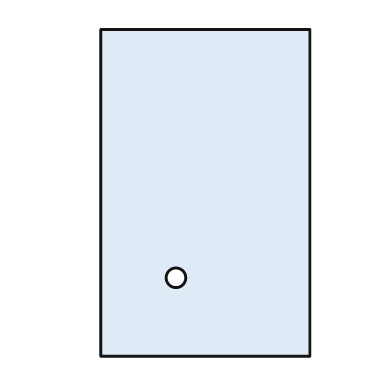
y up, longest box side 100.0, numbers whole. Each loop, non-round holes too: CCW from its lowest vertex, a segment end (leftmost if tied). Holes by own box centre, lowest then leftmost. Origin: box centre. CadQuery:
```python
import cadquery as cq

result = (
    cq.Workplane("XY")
    .moveTo(-32.0, -50.0)
    .lineTo(32.0, -50.0)
    .lineTo(32.0, 50.0)
    .lineTo(-32.0, 50.0)
    .close()
    .moveTo(-9.0, -26.0)
    .circle(3.0)
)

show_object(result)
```